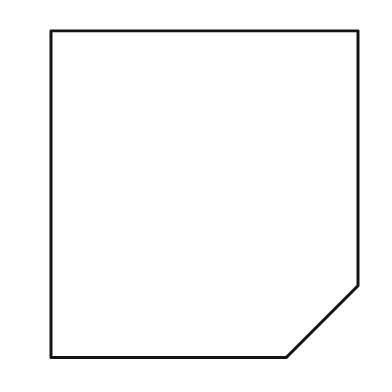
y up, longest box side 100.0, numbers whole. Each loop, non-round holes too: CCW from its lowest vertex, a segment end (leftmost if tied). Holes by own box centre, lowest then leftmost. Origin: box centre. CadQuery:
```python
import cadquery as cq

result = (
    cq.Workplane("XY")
    .moveTo(-47.0, -50.0)
    .lineTo(25.0, -50.0)
    .lineTo(47.0, -28.0)
    .lineTo(47.0, 50.0)
    .lineTo(-47.0, 50.0)
    .close()
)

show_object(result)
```